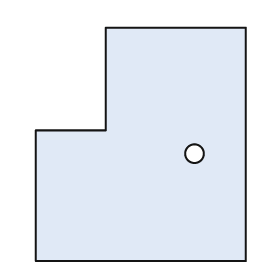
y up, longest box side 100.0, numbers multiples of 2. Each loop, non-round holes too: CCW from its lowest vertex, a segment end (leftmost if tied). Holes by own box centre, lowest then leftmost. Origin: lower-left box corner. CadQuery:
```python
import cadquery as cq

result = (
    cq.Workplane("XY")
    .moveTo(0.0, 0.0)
    .lineTo(90.0, 0.0)
    .lineTo(90.0, 100.0)
    .lineTo(30.0, 100.0)
    .lineTo(30.0, 56.0)
    .lineTo(0.0, 56.0)
    .close()
    .moveTo(68.0, 46.0)
    .circle(4.0)
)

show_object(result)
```